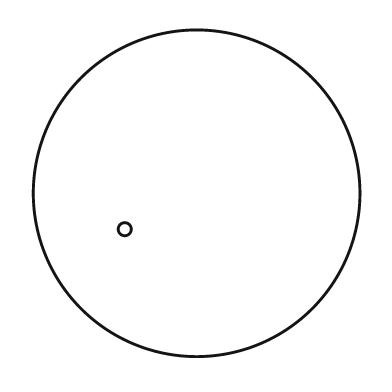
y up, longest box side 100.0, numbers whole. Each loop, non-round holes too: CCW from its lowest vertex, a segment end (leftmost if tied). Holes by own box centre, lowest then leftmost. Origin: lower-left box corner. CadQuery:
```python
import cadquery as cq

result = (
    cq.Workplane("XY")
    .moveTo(50.0, 50.0)
    .circle(50.0)
    .moveTo(28.0, 39.0)
    .circle(2.0)
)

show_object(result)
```